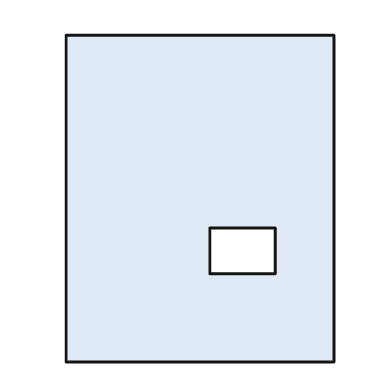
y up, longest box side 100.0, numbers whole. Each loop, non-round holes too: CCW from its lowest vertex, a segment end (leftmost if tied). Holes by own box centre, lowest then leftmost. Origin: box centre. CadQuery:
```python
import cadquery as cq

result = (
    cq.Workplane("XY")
    .moveTo(-41.0, -50.0)
    .lineTo(41.0, -50.0)
    .lineTo(41.0, 50.0)
    .lineTo(-41.0, 50.0)
    .close()
    .moveTo(3.0, -23.0)
    .lineTo(23.0, -23.0)
    .lineTo(23.0, -9.0)
    .lineTo(3.0, -9.0)
    .close()
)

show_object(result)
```